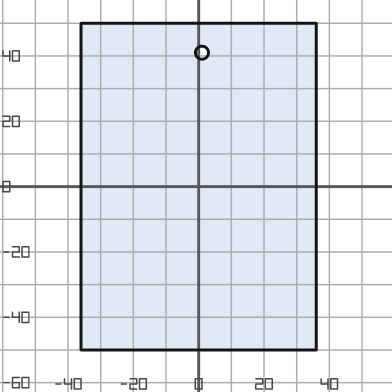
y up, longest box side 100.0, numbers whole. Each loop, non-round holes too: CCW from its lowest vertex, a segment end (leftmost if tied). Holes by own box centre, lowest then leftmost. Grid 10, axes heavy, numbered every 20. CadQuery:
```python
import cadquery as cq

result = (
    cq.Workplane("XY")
    .moveTo(-36.0, -50.0)
    .lineTo(36.0, -50.0)
    .lineTo(36.0, 50.0)
    .lineTo(-36.0, 50.0)
    .close()
    .moveTo(1.0, 41.0)
    .circle(2.0)
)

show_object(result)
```